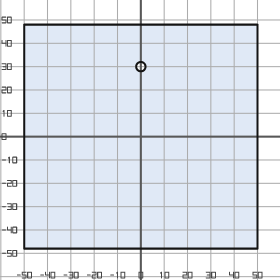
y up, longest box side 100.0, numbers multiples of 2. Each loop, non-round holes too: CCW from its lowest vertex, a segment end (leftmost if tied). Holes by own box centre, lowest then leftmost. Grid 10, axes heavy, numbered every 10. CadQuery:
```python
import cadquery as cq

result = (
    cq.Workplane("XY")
    .moveTo(-50.0, -48.0)
    .lineTo(50.0, -48.0)
    .lineTo(50.0, 48.0)
    .lineTo(-50.0, 48.0)
    .close()
    .moveTo(0.0, 30.0)
    .circle(2.0)
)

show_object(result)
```